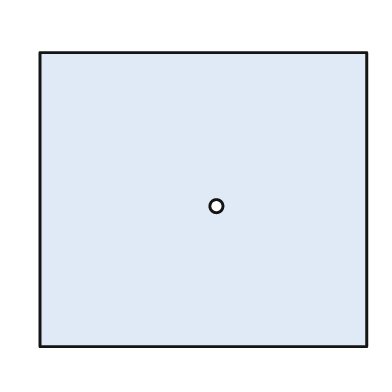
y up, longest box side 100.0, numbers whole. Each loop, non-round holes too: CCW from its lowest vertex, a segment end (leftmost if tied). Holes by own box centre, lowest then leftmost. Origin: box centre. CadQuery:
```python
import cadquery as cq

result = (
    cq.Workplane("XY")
    .moveTo(-50.0, -45.0)
    .lineTo(50.0, -45.0)
    .lineTo(50.0, 45.0)
    .lineTo(-50.0, 45.0)
    .close()
    .moveTo(4.0, -2.0)
    .circle(2.0)
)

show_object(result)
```